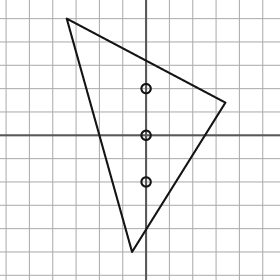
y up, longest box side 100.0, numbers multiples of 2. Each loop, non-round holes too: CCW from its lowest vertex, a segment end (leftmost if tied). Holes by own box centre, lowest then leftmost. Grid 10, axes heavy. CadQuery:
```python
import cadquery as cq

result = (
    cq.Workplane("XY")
    .moveTo(-6.0, -50.0)
    .lineTo(34.0, 14.0)
    .lineTo(-34.0, 50.0)
    .close()
    .moveTo(0.0, -20.0)
    .circle(2.0)
    .moveTo(0.0, 0.0)
    .circle(2.0)
    .moveTo(0.0, 20.0)
    .circle(2.0)
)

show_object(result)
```